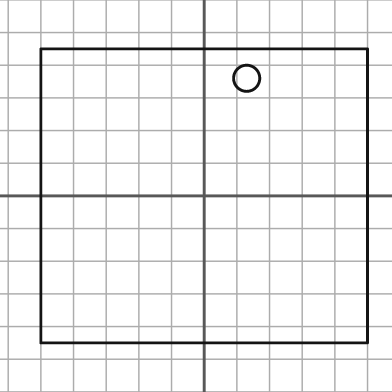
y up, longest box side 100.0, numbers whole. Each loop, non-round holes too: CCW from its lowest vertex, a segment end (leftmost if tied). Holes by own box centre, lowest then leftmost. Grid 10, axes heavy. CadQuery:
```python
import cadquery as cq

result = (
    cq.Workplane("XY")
    .moveTo(-50.0, -45.0)
    .lineTo(50.0, -45.0)
    .lineTo(50.0, 45.0)
    .lineTo(-50.0, 45.0)
    .close()
    .moveTo(13.0, 36.0)
    .circle(4.0)
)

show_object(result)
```